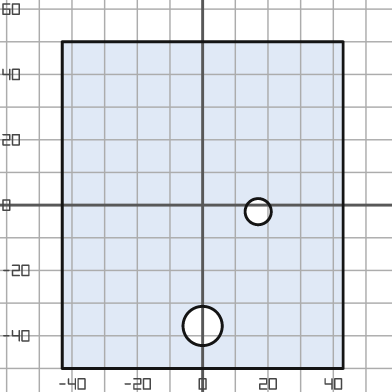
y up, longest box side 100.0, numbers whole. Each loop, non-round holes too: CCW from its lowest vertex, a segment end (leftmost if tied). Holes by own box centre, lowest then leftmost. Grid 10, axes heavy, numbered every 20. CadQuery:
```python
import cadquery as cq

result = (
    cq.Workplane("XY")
    .moveTo(-43.0, -50.0)
    .lineTo(43.0, -50.0)
    .lineTo(43.0, 50.0)
    .lineTo(-43.0, 50.0)
    .close()
    .moveTo(0.0, -37.0)
    .circle(6.0)
    .moveTo(17.0, -2.0)
    .circle(4.0)
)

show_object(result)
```